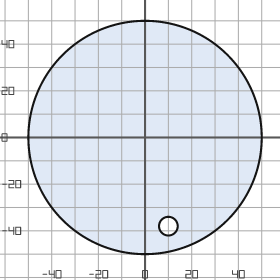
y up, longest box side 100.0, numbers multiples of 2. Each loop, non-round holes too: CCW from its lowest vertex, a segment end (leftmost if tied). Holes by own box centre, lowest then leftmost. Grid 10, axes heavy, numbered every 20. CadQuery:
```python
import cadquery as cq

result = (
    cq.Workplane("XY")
    .moveTo(0.0, 0.0)
    .circle(50.0)
    .moveTo(10.0, -38.0)
    .circle(4.0)
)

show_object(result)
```